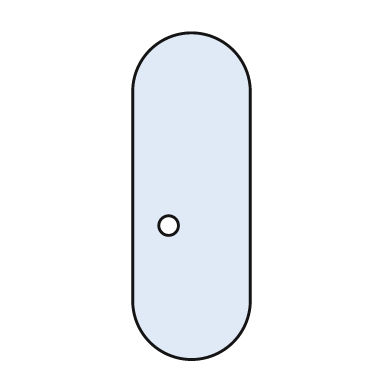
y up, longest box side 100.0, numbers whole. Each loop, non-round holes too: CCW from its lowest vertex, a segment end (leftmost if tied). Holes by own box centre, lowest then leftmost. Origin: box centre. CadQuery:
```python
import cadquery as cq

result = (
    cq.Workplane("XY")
    .moveTo(-18.0, -32.0)
    .threePointArc((0.0, -50.0), (18.0, -32.0))
    .lineTo(18.0, 32.0)
    .threePointArc((0.0, 50.0), (-18.0, 32.0))
    .close()
    .moveTo(-7.0, -9.0)
    .circle(3.0)
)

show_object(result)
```